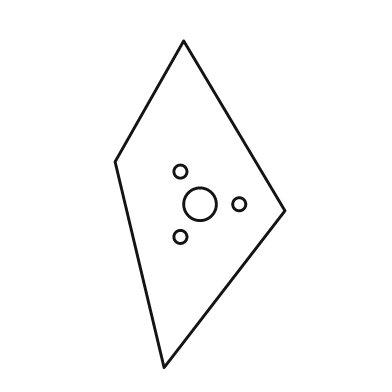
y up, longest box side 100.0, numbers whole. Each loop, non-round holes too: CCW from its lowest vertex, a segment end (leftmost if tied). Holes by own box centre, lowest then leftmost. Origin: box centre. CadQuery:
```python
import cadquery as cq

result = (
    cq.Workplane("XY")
    .moveTo(-11.0, -50.0)
    .lineTo(26.0, -2.0)
    .lineTo(-5.0, 50.0)
    .lineTo(-26.0, 13.0)
    .close()
    .moveTo(-6.0, -10.0)
    .circle(2.0)
    .moveTo(0.0, 0.0)
    .circle(5.0)
    .moveTo(12.0, 0.0)
    .circle(2.0)
    .moveTo(-6.0, 10.0)
    .circle(2.0)
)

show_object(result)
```